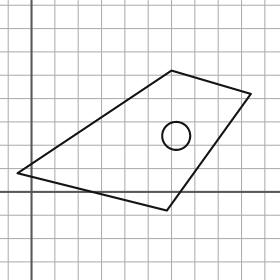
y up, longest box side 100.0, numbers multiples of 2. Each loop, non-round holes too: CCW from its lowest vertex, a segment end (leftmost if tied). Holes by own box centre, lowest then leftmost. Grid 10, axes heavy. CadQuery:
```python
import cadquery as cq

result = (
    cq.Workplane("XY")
    .moveTo(58.0, -8.0)
    .lineTo(94.0, 42.0)
    .lineTo(60.0, 52.0)
    .lineTo(-6.0, 8.0)
    .close()
    .moveTo(62.0, 24.0)
    .circle(6.0)
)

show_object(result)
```